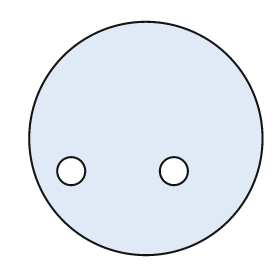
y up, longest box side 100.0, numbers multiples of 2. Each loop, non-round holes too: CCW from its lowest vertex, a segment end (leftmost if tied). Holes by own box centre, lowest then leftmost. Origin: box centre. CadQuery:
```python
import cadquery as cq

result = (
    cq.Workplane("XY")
    .moveTo(0.0, 0.0)
    .circle(50.0)
    .moveTo(-32.0, -14.0)
    .circle(6.0)
    .moveTo(12.0, -14.0)
    .circle(6.0)
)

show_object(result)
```